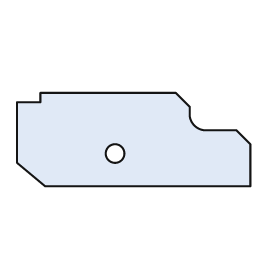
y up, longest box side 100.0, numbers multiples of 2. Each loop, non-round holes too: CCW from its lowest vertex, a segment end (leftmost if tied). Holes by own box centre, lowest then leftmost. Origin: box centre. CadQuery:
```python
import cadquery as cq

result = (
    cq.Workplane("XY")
    .moveTo(-38.0, -20.0)
    .lineTo(50.0, -20.0)
    .lineTo(50.0, -2.0)
    .lineTo(44.0, 4.0)
    .lineTo(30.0, 4.0)
    .threePointArc((26.0, 6.0), (24.0, 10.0))
    .lineTo(24.0, 14.0)
    .lineTo(18.0, 20.0)
    .lineTo(-40.0, 20.0)
    .lineTo(-40.0, 16.0)
    .lineTo(-50.0, 16.0)
    .lineTo(-50.0, -10.0)
    .close()
    .moveTo(-8.0, -6.0)
    .circle(4.0)
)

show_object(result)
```